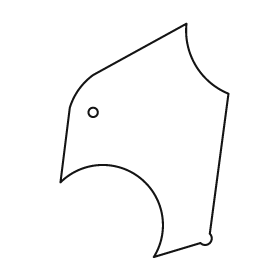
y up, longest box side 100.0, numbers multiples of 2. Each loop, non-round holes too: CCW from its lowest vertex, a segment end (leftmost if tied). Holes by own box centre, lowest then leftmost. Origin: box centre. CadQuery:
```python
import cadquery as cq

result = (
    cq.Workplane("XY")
    .moveTo(4.0, -50.0)
    .lineTo(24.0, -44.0)
    .threePointArc((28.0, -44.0), (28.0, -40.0))
    .lineTo(36.0, 20.0)
    .threePointArc((22.0, 32.0), (18.0, 50.0))
    .lineTo(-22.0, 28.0)
    .threePointArc((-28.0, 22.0), (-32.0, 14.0))
    .lineTo(-36.0, -18.0)
    .threePointArc((-2.0, -16.0), (4.0, -50.0))
    .close()
    .moveTo(-22.0, 12.0)
    .circle(2.0)
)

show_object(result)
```